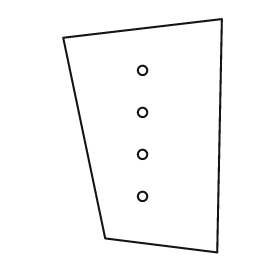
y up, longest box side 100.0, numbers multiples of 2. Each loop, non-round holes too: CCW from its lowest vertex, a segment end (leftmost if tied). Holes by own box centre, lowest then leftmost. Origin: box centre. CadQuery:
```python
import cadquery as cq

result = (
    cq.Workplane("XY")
    .moveTo(32.0, -50.0)
    .lineTo(34.0, 50.0)
    .lineTo(-34.0, 42.0)
    .lineTo(-16.0, -44.0)
    .close()
    .moveTo(0.0, -26.0)
    .circle(2.0)
    .moveTo(0.0, -8.0)
    .circle(2.0)
    .moveTo(0.0, 10.0)
    .circle(2.0)
    .moveTo(0.0, 28.0)
    .circle(2.0)
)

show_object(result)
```